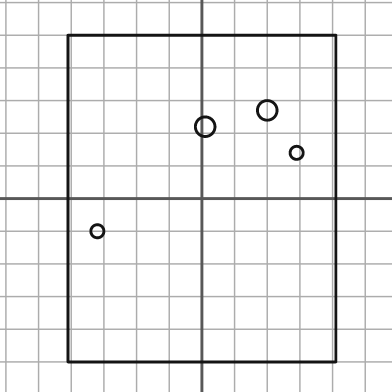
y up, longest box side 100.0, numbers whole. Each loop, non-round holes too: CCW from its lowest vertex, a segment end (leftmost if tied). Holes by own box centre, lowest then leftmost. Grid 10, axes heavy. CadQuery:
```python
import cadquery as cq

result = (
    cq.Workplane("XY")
    .moveTo(-41.0, -50.0)
    .lineTo(41.0, -50.0)
    .lineTo(41.0, 50.0)
    .lineTo(-41.0, 50.0)
    .close()
    .moveTo(-32.0, -10.0)
    .circle(2.0)
    .moveTo(29.0, 14.0)
    .circle(2.0)
    .moveTo(1.0, 22.0)
    .circle(3.0)
    .moveTo(20.0, 27.0)
    .circle(3.0)
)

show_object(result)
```